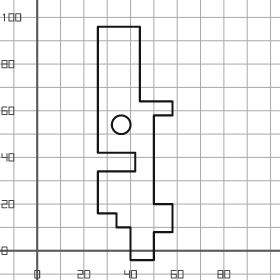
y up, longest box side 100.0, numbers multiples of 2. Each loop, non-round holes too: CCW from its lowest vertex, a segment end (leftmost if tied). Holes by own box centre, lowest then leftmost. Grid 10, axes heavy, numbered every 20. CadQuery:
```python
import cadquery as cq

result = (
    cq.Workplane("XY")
    .moveTo(40.0, -4.0)
    .lineTo(50.0, -4.0)
    .lineTo(50.0, 8.0)
    .lineTo(58.0, 8.0)
    .lineTo(58.0, 20.0)
    .lineTo(50.0, 20.0)
    .lineTo(50.0, 58.0)
    .lineTo(58.0, 58.0)
    .lineTo(58.0, 64.0)
    .lineTo(44.0, 64.0)
    .lineTo(44.0, 96.0)
    .lineTo(26.0, 96.0)
    .lineTo(26.0, 42.0)
    .lineTo(42.0, 42.0)
    .lineTo(42.0, 34.0)
    .lineTo(26.0, 34.0)
    .lineTo(26.0, 16.0)
    .lineTo(34.0, 16.0)
    .lineTo(34.0, 10.0)
    .lineTo(40.0, 10.0)
    .close()
    .moveTo(36.0, 54.0)
    .circle(4.0)
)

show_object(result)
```